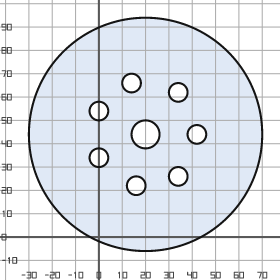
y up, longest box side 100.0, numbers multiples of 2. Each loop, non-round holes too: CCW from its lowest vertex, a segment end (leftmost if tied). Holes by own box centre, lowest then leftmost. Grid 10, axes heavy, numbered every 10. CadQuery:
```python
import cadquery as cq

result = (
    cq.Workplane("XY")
    .moveTo(20.0, 44.0)
    .circle(50.0)
    .moveTo(16.0, 22.0)
    .circle(4.0)
    .moveTo(34.0, 26.0)
    .circle(4.0)
    .moveTo(0.0, 34.0)
    .circle(4.0)
    .moveTo(20.0, 44.0)
    .circle(6.0)
    .moveTo(42.0, 44.0)
    .circle(4.0)
    .moveTo(0.0, 54.0)
    .circle(4.0)
    .moveTo(34.0, 62.0)
    .circle(4.0)
    .moveTo(14.0, 66.0)
    .circle(4.0)
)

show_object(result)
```